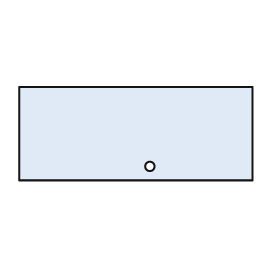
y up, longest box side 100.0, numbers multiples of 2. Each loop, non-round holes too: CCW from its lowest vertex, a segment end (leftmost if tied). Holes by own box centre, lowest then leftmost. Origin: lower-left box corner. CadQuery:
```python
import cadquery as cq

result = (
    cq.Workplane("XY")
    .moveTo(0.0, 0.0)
    .lineTo(100.0, 0.0)
    .lineTo(100.0, 40.0)
    .lineTo(0.0, 40.0)
    .close()
    .moveTo(56.0, 6.0)
    .circle(2.0)
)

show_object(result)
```